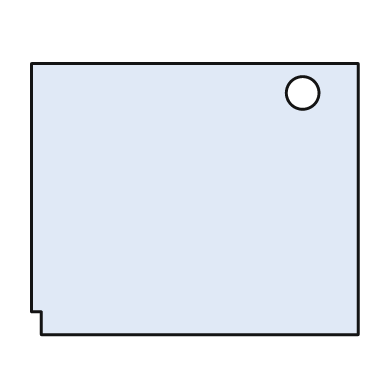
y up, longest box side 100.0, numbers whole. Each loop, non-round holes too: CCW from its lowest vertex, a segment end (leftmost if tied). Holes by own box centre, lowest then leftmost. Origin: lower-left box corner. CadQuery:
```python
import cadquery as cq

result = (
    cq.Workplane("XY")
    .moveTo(3.0, 0.0)
    .lineTo(100.0, 0.0)
    .lineTo(100.0, 83.0)
    .lineTo(0.0, 83.0)
    .lineTo(0.0, 7.0)
    .lineTo(3.0, 7.0)
    .close()
    .moveTo(83.0, 74.0)
    .circle(5.0)
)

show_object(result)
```